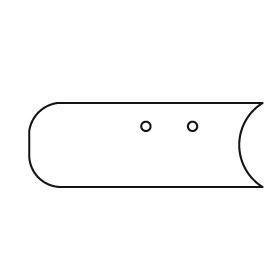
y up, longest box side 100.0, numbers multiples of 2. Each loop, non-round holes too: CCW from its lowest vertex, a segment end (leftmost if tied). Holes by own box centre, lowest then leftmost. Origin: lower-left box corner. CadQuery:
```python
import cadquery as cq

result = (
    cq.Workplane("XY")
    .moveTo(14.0, 0.0)
    .lineTo(100.0, 0.0)
    .threePointArc((90.0, 18.0), (100.0, 36.0))
    .lineTo(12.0, 36.0)
    .threePointArc((4.0, 32.0), (0.0, 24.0))
    .lineTo(0.0, 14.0)
    .threePointArc((4.0, 4.0), (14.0, 0.0))
    .close()
    .moveTo(50.0, 26.0)
    .circle(2.0)
    .moveTo(70.0, 26.0)
    .circle(2.0)
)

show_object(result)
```